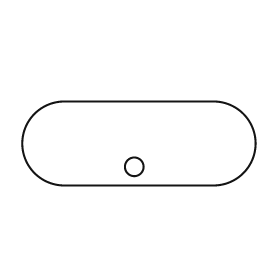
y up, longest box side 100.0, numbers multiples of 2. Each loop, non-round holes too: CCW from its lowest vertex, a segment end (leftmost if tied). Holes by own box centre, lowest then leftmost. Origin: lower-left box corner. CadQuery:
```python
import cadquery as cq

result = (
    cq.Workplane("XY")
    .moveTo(18.0, 0.0)
    .lineTo(82.0, 0.0)
    .threePointArc((100.0, 18.0), (82.0, 36.0))
    .lineTo(18.0, 36.0)
    .threePointArc((0.0, 18.0), (18.0, 0.0))
    .close()
    .moveTo(48.0, 8.0)
    .circle(4.0)
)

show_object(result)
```